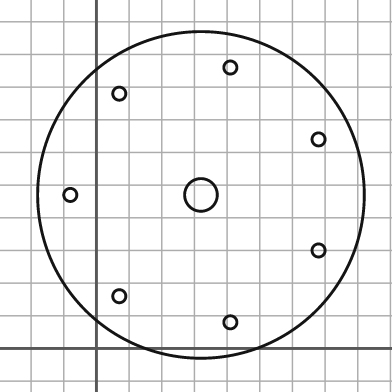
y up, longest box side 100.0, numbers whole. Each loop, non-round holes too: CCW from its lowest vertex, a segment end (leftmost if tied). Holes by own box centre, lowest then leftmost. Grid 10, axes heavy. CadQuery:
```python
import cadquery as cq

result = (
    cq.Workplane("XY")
    .moveTo(32.0, 47.0)
    .circle(50.0)
    .moveTo(41.0, 8.0)
    .circle(2.0)
    .moveTo(7.0, 16.0)
    .circle(2.0)
    .moveTo(68.0, 30.0)
    .circle(2.0)
    .moveTo(-8.0, 47.0)
    .circle(2.0)
    .moveTo(32.0, 47.0)
    .circle(5.0)
    .moveTo(68.0, 64.0)
    .circle(2.0)
    .moveTo(7.0, 78.0)
    .circle(2.0)
    .moveTo(41.0, 86.0)
    .circle(2.0)
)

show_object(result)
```